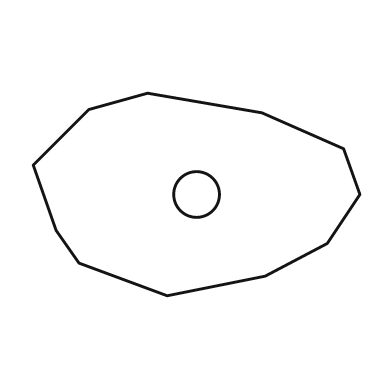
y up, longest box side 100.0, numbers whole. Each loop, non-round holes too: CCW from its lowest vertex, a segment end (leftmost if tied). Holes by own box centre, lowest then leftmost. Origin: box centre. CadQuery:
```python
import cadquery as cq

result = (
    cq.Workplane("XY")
    .moveTo(-9.0, -31.0)
    .lineTo(21.0, -25.0)
    .lineTo(40.0, -15.0)
    .lineTo(50.0, 0.0)
    .lineTo(45.0, 14.0)
    .lineTo(20.0, 25.0)
    .lineTo(-15.0, 31.0)
    .lineTo(-33.0, 26.0)
    .lineTo(-50.0, 9.0)
    .lineTo(-43.0, -11.0)
    .lineTo(-36.0, -21.0)
    .close()
    .moveTo(0.0, 0.0)
    .circle(7.0)
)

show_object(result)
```